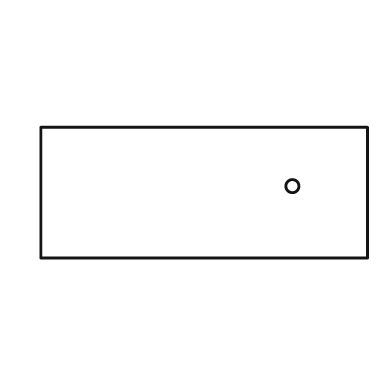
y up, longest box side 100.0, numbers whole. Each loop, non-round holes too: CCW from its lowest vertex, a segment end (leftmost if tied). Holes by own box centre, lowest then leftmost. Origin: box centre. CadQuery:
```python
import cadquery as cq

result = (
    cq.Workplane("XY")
    .moveTo(-50.0, -20.0)
    .lineTo(50.0, -20.0)
    .lineTo(50.0, 20.0)
    .lineTo(-50.0, 20.0)
    .close()
    .moveTo(27.0, 2.0)
    .circle(2.0)
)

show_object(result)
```